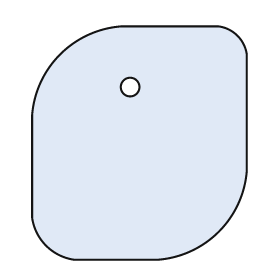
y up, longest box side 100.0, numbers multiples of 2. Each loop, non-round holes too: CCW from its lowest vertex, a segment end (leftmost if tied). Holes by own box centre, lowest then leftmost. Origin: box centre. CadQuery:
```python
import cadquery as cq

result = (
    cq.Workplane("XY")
    .moveTo(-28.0, -50.0)
    .lineTo(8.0, -50.0)
    .threePointArc((34.0, -38.0), (46.0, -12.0))
    .lineTo(46.0, 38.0)
    .threePointArc((42.0, 46.0), (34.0, 50.0))
    .lineTo(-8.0, 50.0)
    .threePointArc((-34.0, 38.0), (-46.0, 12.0))
    .lineTo(-46.0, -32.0)
    .threePointArc((-40.0, -44.0), (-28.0, -50.0))
    .close()
    .moveTo(-4.0, 24.0)
    .circle(4.0)
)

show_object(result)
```